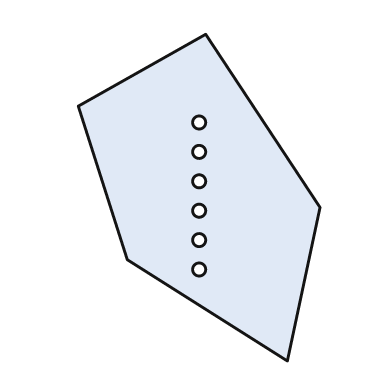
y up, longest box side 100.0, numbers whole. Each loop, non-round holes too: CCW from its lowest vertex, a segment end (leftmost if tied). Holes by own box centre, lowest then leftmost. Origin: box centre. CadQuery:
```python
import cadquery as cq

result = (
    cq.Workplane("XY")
    .moveTo(27.0, -50.0)
    .lineTo(37.0, -3.0)
    .lineTo(2.0, 50.0)
    .lineTo(-37.0, 28.0)
    .lineTo(-22.0, -19.0)
    .close()
    .moveTo(0.0, -22.0)
    .circle(2.0)
    .moveTo(0.0, -13.0)
    .circle(2.0)
    .moveTo(0.0, -4.0)
    .circle(2.0)
    .moveTo(0.0, 5.0)
    .circle(2.0)
    .moveTo(0.0, 14.0)
    .circle(2.0)
    .moveTo(0.0, 23.0)
    .circle(2.0)
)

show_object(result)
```